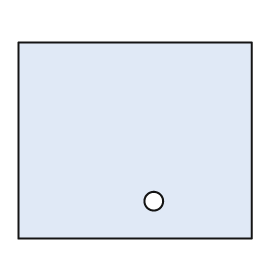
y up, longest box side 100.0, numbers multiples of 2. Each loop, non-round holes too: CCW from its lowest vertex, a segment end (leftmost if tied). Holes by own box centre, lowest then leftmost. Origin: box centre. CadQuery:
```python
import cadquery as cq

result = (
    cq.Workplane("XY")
    .moveTo(-50.0, -42.0)
    .lineTo(50.0, -42.0)
    .lineTo(50.0, 42.0)
    .lineTo(-50.0, 42.0)
    .close()
    .moveTo(8.0, -26.0)
    .circle(4.0)
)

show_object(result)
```